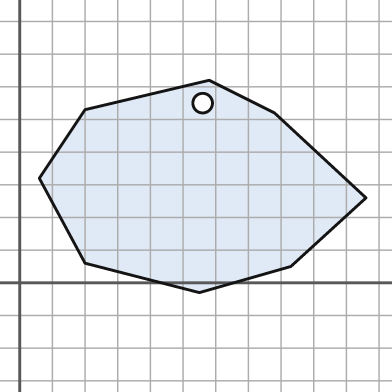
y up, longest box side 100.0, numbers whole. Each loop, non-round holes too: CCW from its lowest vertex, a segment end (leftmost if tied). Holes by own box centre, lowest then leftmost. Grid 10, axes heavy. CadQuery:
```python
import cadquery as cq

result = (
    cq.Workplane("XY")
    .moveTo(55.0, -3.0)
    .lineTo(83.0, 5.0)
    .lineTo(106.0, 26.0)
    .lineTo(78.0, 52.0)
    .lineTo(58.0, 62.0)
    .lineTo(20.0, 53.0)
    .lineTo(6.0, 32.0)
    .lineTo(20.0, 6.0)
    .close()
    .moveTo(56.0, 55.0)
    .circle(3.0)
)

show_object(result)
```